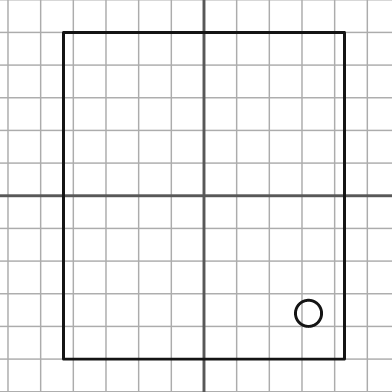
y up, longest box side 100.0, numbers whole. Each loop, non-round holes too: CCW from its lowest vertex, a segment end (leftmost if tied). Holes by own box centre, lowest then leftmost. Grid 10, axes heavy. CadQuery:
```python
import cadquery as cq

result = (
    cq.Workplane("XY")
    .moveTo(-43.0, -50.0)
    .lineTo(43.0, -50.0)
    .lineTo(43.0, 50.0)
    .lineTo(-43.0, 50.0)
    .close()
    .moveTo(32.0, -36.0)
    .circle(4.0)
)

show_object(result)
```